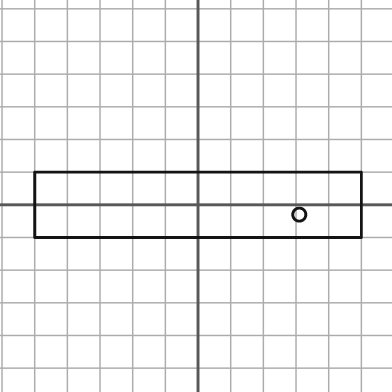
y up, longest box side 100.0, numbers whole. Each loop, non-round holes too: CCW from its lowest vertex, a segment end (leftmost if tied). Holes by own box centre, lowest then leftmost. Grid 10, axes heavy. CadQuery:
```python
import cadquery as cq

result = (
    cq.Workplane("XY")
    .moveTo(-50.0, -10.0)
    .lineTo(50.0, -10.0)
    .lineTo(50.0, 10.0)
    .lineTo(-50.0, 10.0)
    .close()
    .moveTo(31.0, -3.0)
    .circle(2.0)
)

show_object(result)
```